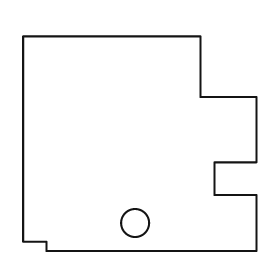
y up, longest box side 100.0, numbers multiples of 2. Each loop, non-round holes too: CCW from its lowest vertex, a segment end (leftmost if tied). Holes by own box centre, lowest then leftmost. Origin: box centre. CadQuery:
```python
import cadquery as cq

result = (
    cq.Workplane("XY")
    .moveTo(-40.0, -46.0)
    .lineTo(50.0, -46.0)
    .lineTo(50.0, -22.0)
    .lineTo(32.0, -22.0)
    .lineTo(32.0, -8.0)
    .lineTo(50.0, -8.0)
    .lineTo(50.0, 20.0)
    .lineTo(26.0, 20.0)
    .lineTo(26.0, 46.0)
    .lineTo(-50.0, 46.0)
    .lineTo(-50.0, -42.0)
    .lineTo(-40.0, -42.0)
    .close()
    .moveTo(-2.0, -34.0)
    .circle(6.0)
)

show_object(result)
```